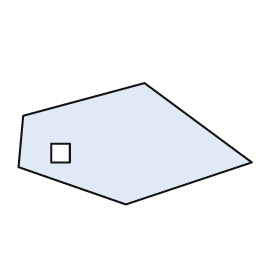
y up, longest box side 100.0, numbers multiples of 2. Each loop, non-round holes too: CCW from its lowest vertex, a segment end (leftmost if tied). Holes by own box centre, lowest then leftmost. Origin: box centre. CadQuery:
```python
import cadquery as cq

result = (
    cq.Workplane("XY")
    .moveTo(-4.0, -26.0)
    .lineTo(50.0, -8.0)
    .lineTo(4.0, 26.0)
    .lineTo(-48.0, 12.0)
    .lineTo(-50.0, -10.0)
    .close()
    .moveTo(-36.0, -8.0)
    .lineTo(-28.0, -8.0)
    .lineTo(-28.0, 0.0)
    .lineTo(-36.0, 0.0)
    .close()
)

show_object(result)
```